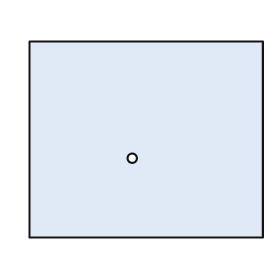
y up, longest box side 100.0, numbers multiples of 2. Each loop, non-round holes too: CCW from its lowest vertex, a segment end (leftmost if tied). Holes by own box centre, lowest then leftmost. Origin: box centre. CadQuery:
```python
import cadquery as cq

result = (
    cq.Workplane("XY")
    .moveTo(-50.0, -42.0)
    .lineTo(50.0, -42.0)
    .lineTo(50.0, 42.0)
    .lineTo(-50.0, 42.0)
    .close()
    .moveTo(-6.0, -8.0)
    .circle(2.0)
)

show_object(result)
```